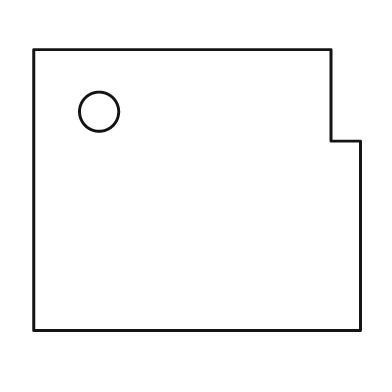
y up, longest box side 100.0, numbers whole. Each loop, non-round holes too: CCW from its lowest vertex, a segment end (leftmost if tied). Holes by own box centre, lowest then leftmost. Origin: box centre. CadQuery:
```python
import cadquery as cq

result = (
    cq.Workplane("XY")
    .moveTo(-50.0, -43.0)
    .lineTo(50.0, -43.0)
    .lineTo(50.0, 15.0)
    .lineTo(41.0, 15.0)
    .lineTo(41.0, 43.0)
    .lineTo(-50.0, 43.0)
    .close()
    .moveTo(-30.0, 24.0)
    .circle(6.0)
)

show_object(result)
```